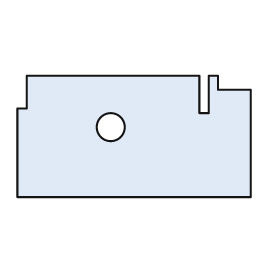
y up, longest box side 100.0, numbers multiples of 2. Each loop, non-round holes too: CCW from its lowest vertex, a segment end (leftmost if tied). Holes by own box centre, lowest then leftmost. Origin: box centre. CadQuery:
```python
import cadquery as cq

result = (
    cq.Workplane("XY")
    .moveTo(-50.0, -26.0)
    .lineTo(50.0, -26.0)
    .lineTo(50.0, 20.0)
    .lineTo(36.0, 20.0)
    .lineTo(36.0, 26.0)
    .lineTo(32.0, 26.0)
    .lineTo(32.0, 10.0)
    .lineTo(28.0, 10.0)
    .lineTo(28.0, 26.0)
    .lineTo(-46.0, 26.0)
    .lineTo(-46.0, 12.0)
    .lineTo(-50.0, 12.0)
    .close()
    .moveTo(-10.0, 4.0)
    .circle(6.0)
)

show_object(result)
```